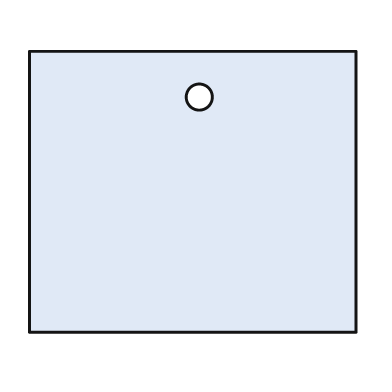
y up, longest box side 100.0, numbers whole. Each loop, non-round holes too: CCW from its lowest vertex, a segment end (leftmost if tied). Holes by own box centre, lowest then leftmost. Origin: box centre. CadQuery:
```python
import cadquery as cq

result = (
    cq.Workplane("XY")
    .moveTo(-50.0, -43.0)
    .lineTo(50.0, -43.0)
    .lineTo(50.0, 43.0)
    .lineTo(-50.0, 43.0)
    .close()
    .moveTo(2.0, 29.0)
    .circle(4.0)
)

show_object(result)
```